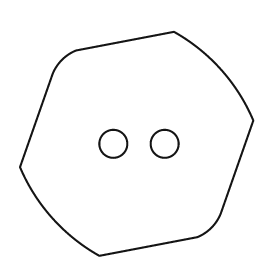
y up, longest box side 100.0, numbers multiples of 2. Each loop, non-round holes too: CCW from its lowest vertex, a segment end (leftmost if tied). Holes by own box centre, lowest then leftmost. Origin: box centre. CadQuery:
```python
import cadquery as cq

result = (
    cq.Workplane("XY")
    .moveTo(-16.0, -48.0)
    .lineTo(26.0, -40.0)
    .threePointArc((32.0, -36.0), (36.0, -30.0))
    .lineTo(50.0, 10.0)
    .threePointArc((36.0, 32.0), (16.0, 48.0))
    .lineTo(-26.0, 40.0)
    .threePointArc((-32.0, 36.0), (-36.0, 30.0))
    .lineTo(-50.0, -10.0)
    .threePointArc((-36.0, -32.0), (-16.0, -48.0))
    .close()
    .moveTo(-10.0, 0.0)
    .circle(6.0)
    .moveTo(12.0, 0.0)
    .circle(6.0)
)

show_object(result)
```